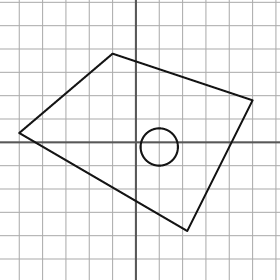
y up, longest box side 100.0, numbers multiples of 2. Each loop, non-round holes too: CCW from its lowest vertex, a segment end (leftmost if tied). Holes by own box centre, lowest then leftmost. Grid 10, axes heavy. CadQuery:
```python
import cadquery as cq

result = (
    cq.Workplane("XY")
    .moveTo(22.0, -38.0)
    .lineTo(50.0, 18.0)
    .lineTo(-10.0, 38.0)
    .lineTo(-50.0, 4.0)
    .close()
    .moveTo(10.0, -2.0)
    .circle(8.0)
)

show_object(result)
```